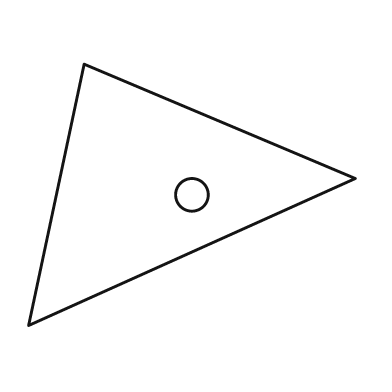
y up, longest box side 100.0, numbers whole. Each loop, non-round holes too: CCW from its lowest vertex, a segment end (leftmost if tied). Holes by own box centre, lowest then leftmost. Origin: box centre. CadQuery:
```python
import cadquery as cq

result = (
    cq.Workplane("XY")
    .moveTo(-50.0, -40.0)
    .lineTo(50.0, 5.0)
    .lineTo(-33.0, 40.0)
    .close()
    .moveTo(0.0, 0.0)
    .circle(5.0)
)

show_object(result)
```